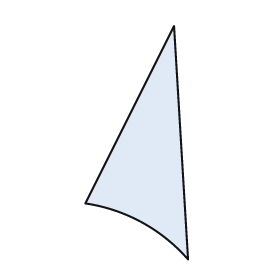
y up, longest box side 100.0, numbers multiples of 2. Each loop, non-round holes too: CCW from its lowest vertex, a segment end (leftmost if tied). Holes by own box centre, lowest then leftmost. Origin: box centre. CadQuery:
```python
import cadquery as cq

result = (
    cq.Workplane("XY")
    .moveTo(22.0, -50.0)
    .lineTo(16.0, 50.0)
    .lineTo(-22.0, -26.0)
    .threePointArc((2.0, -34.0), (22.0, -50.0))
    .close()
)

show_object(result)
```